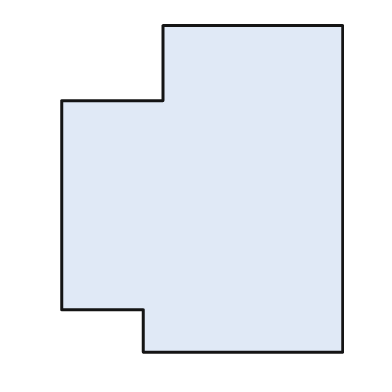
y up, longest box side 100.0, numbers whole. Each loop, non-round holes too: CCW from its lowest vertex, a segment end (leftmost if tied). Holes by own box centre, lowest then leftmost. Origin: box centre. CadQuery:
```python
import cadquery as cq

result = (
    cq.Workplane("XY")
    .moveTo(-18.0, -50.0)
    .lineTo(43.0, -50.0)
    .lineTo(43.0, 50.0)
    .lineTo(-12.0, 50.0)
    .lineTo(-12.0, 27.0)
    .lineTo(-43.0, 27.0)
    .lineTo(-43.0, -37.0)
    .lineTo(-18.0, -37.0)
    .close()
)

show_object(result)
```